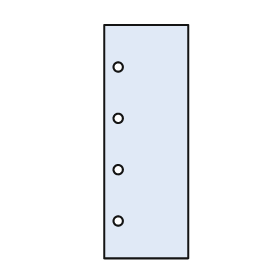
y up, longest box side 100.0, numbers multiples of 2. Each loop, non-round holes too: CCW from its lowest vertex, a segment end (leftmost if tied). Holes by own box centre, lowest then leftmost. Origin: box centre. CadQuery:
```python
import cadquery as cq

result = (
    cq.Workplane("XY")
    .moveTo(-18.0, -50.0)
    .lineTo(18.0, -50.0)
    .lineTo(18.0, 50.0)
    .lineTo(-18.0, 50.0)
    .close()
    .moveTo(-12.0, -34.0)
    .circle(2.0)
    .moveTo(-12.0, -12.0)
    .circle(2.0)
    .moveTo(-12.0, 10.0)
    .circle(2.0)
    .moveTo(-12.0, 32.0)
    .circle(2.0)
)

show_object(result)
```